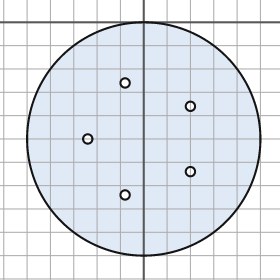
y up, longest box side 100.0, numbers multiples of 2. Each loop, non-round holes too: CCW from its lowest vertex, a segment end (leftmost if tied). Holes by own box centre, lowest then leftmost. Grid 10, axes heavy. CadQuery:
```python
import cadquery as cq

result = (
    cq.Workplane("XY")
    .moveTo(0.0, -50.0)
    .circle(50.0)
    .moveTo(-8.0, -74.0)
    .circle(2.0)
    .moveTo(20.0, -64.0)
    .circle(2.0)
    .moveTo(-24.0, -50.0)
    .circle(2.0)
    .moveTo(20.0, -36.0)
    .circle(2.0)
    .moveTo(-8.0, -26.0)
    .circle(2.0)
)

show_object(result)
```